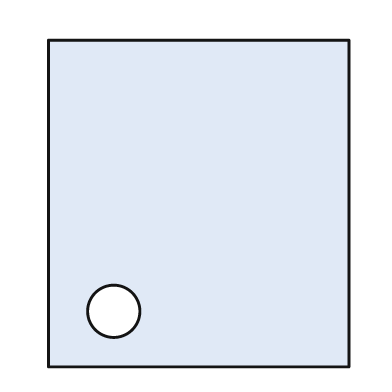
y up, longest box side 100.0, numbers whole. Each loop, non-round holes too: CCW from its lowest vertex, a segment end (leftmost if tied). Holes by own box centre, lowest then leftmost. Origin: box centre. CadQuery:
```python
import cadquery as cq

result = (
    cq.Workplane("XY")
    .moveTo(-46.0, -50.0)
    .lineTo(46.0, -50.0)
    .lineTo(46.0, 50.0)
    .lineTo(-46.0, 50.0)
    .close()
    .moveTo(-26.0, -33.0)
    .circle(8.0)
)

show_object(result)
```